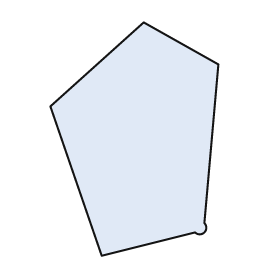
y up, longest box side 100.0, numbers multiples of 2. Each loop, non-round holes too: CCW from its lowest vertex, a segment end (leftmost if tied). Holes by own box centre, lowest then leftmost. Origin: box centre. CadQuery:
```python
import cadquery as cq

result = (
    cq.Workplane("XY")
    .moveTo(-14.0, -50.0)
    .lineTo(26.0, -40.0)
    .threePointArc((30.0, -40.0), (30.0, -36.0))
    .lineTo(36.0, 32.0)
    .lineTo(4.0, 50.0)
    .lineTo(-36.0, 14.0)
    .close()
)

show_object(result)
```